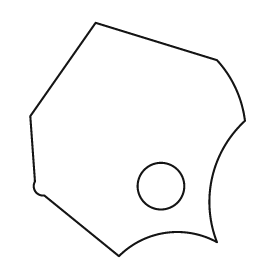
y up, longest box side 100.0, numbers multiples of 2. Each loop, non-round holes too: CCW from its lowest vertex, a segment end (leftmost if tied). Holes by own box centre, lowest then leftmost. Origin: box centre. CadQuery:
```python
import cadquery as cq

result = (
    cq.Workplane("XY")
    .moveTo(-8.0, -50.0)
    .threePointArc((12.0, -40.0), (34.0, -44.0))
    .threePointArc((32.0, -16.0), (46.0, 8.0))
    .threePointArc((42.0, 22.0), (34.0, 34.0))
    .lineTo(-18.0, 50.0)
    .lineTo(-46.0, 10.0)
    .lineTo(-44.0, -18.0)
    .threePointArc((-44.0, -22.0), (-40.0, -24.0))
    .close()
    .moveTo(10.0, -20.0)
    .circle(10.0)
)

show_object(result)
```